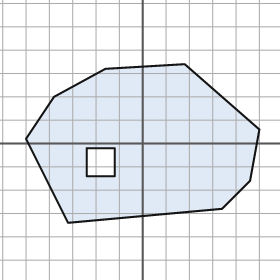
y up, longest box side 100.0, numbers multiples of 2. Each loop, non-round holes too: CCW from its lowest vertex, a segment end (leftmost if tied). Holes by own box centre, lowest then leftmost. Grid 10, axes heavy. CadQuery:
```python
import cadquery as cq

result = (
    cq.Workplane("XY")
    .moveTo(-32.0, -34.0)
    .lineTo(34.0, -28.0)
    .lineTo(46.0, -16.0)
    .lineTo(50.0, 6.0)
    .lineTo(18.0, 34.0)
    .lineTo(-16.0, 32.0)
    .lineTo(-38.0, 20.0)
    .lineTo(-50.0, 2.0)
    .close()
    .moveTo(-24.0, -14.0)
    .lineTo(-12.0, -14.0)
    .lineTo(-12.0, -2.0)
    .lineTo(-24.0, -2.0)
    .close()
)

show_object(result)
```